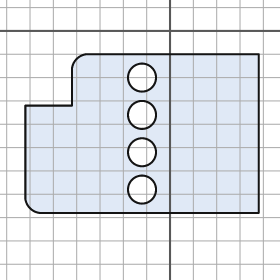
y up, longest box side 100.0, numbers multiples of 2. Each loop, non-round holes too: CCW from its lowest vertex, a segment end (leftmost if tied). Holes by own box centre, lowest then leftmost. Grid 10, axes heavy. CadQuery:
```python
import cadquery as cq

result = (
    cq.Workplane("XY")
    .moveTo(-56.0, -78.0)
    .lineTo(38.0, -78.0)
    .lineTo(38.0, -10.0)
    .lineTo(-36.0, -10.0)
    .threePointArc((-40.0, -12.0), (-42.0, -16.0))
    .lineTo(-42.0, -32.0)
    .lineTo(-62.0, -32.0)
    .lineTo(-62.0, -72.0)
    .threePointArc((-60.0, -76.0), (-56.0, -78.0))
    .close()
    .moveTo(-12.0, -68.0)
    .circle(6.0)
    .moveTo(-12.0, -52.0)
    .circle(6.0)
    .moveTo(-12.0, -36.0)
    .circle(6.0)
    .moveTo(-12.0, -20.0)
    .circle(6.0)
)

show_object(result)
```